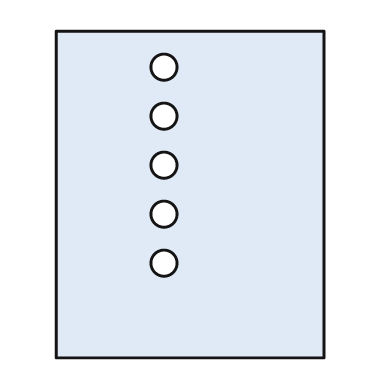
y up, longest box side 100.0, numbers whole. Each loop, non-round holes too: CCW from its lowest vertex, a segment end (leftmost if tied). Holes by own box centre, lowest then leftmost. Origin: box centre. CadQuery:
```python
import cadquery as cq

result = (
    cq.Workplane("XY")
    .moveTo(-41.0, -50.0)
    .lineTo(41.0, -50.0)
    .lineTo(41.0, 50.0)
    .lineTo(-41.0, 50.0)
    .close()
    .moveTo(-8.0, -21.0)
    .circle(4.0)
    .moveTo(-8.0, -6.0)
    .circle(4.0)
    .moveTo(-8.0, 9.0)
    .circle(4.0)
    .moveTo(-8.0, 24.0)
    .circle(4.0)
    .moveTo(-8.0, 39.0)
    .circle(4.0)
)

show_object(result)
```